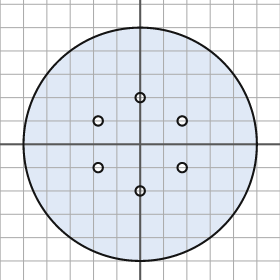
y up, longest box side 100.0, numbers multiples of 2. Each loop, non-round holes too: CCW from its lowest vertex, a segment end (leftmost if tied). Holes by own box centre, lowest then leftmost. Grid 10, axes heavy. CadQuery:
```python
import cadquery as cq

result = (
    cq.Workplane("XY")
    .moveTo(0.0, 0.0)
    .circle(50.0)
    .moveTo(0.0, -20.0)
    .circle(2.0)
    .moveTo(-18.0, -10.0)
    .circle(2.0)
    .moveTo(18.0, -10.0)
    .circle(2.0)
    .moveTo(-18.0, 10.0)
    .circle(2.0)
    .moveTo(18.0, 10.0)
    .circle(2.0)
    .moveTo(0.0, 20.0)
    .circle(2.0)
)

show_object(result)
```